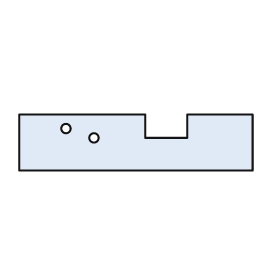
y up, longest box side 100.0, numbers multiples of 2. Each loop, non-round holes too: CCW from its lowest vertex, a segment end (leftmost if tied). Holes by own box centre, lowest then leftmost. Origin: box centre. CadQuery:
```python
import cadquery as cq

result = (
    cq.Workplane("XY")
    .moveTo(-50.0, -12.0)
    .lineTo(50.0, -12.0)
    .lineTo(50.0, 12.0)
    .lineTo(22.0, 12.0)
    .lineTo(22.0, 2.0)
    .lineTo(4.0, 2.0)
    .lineTo(4.0, 12.0)
    .lineTo(-50.0, 12.0)
    .close()
    .moveTo(-18.0, 2.0)
    .circle(2.0)
    .moveTo(-30.0, 6.0)
    .circle(2.0)
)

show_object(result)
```